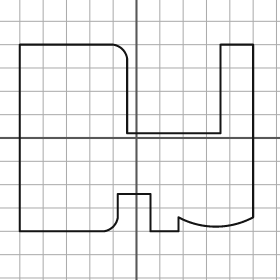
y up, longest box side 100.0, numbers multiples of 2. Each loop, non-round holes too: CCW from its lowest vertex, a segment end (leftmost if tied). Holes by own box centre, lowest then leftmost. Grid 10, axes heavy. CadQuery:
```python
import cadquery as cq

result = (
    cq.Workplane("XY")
    .moveTo(-50.0, -40.0)
    .lineTo(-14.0, -40.0)
    .threePointArc((-10.0, -38.0), (-8.0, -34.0))
    .lineTo(-8.0, -24.0)
    .lineTo(6.0, -24.0)
    .lineTo(6.0, -40.0)
    .lineTo(18.0, -40.0)
    .lineTo(18.0, -34.0)
    .threePointArc((34.0, -38.0), (50.0, -34.0))
    .lineTo(50.0, 40.0)
    .lineTo(36.0, 40.0)
    .lineTo(36.0, 2.0)
    .lineTo(-4.0, 2.0)
    .lineTo(-4.0, 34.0)
    .threePointArc((-6.0, 38.0), (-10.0, 40.0))
    .lineTo(-50.0, 40.0)
    .close()
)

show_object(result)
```